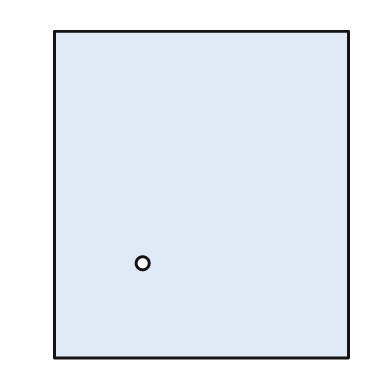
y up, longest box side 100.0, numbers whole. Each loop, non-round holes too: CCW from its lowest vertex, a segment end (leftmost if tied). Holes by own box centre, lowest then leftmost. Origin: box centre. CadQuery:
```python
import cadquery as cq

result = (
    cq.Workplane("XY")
    .moveTo(-45.0, -50.0)
    .lineTo(45.0, -50.0)
    .lineTo(45.0, 50.0)
    .lineTo(-45.0, 50.0)
    .close()
    .moveTo(-18.0, -21.0)
    .circle(2.0)
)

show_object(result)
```